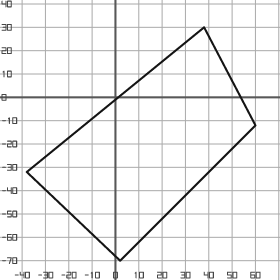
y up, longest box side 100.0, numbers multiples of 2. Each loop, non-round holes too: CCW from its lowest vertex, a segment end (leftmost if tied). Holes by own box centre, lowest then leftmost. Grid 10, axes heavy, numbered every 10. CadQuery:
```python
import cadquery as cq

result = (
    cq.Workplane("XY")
    .moveTo(2.0, -70.0)
    .lineTo(60.0, -12.0)
    .lineTo(38.0, 30.0)
    .lineTo(-38.0, -32.0)
    .close()
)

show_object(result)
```